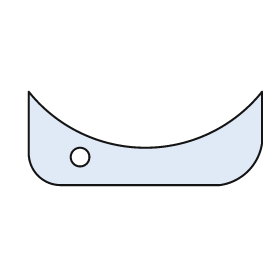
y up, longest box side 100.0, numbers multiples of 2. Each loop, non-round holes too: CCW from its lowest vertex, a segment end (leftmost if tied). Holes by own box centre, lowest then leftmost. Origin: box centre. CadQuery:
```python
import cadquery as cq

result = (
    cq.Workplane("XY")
    .moveTo(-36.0, -20.0)
    .lineTo(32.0, -20.0)
    .threePointArc((44.0, -14.0), (50.0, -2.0))
    .lineTo(50.0, 20.0)
    .threePointArc((0.0, -4.0), (-50.0, 20.0))
    .lineTo(-50.0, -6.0)
    .threePointArc((-46.0, -16.0), (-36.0, -20.0))
    .close()
    .moveTo(-28.0, -8.0)
    .circle(4.0)
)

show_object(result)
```